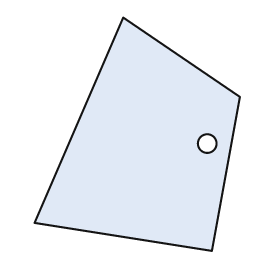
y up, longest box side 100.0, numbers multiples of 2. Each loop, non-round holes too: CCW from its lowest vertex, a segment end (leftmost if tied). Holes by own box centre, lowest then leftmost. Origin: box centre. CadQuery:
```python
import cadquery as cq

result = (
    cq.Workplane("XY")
    .moveTo(32.0, -50.0)
    .lineTo(44.0, 16.0)
    .lineTo(-6.0, 50.0)
    .lineTo(-44.0, -38.0)
    .close()
    .moveTo(30.0, -4.0)
    .circle(4.0)
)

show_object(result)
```